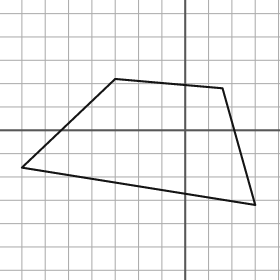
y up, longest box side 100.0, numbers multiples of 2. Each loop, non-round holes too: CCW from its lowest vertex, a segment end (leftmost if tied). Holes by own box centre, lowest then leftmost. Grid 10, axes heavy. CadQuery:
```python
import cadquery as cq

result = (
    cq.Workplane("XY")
    .moveTo(30.0, -32.0)
    .lineTo(16.0, 18.0)
    .lineTo(-30.0, 22.0)
    .lineTo(-70.0, -16.0)
    .close()
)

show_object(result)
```